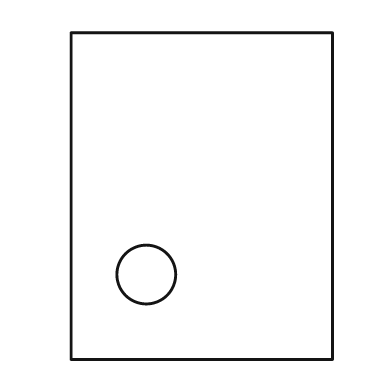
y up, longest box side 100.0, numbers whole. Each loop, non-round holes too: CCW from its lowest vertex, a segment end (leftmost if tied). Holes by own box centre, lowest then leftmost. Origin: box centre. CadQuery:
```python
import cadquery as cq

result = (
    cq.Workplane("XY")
    .moveTo(-40.0, -50.0)
    .lineTo(40.0, -50.0)
    .lineTo(40.0, 50.0)
    .lineTo(-40.0, 50.0)
    .close()
    .moveTo(-17.0, -24.0)
    .circle(9.0)
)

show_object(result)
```